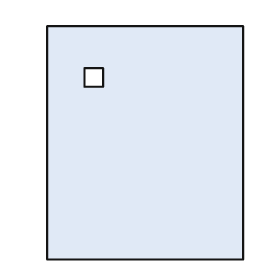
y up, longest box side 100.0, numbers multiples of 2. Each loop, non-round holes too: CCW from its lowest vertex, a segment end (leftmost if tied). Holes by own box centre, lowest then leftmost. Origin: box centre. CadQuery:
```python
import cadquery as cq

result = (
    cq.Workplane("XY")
    .moveTo(-42.0, -50.0)
    .lineTo(42.0, -50.0)
    .lineTo(42.0, 50.0)
    .lineTo(-42.0, 50.0)
    .close()
    .moveTo(-26.0, 24.0)
    .lineTo(-18.0, 24.0)
    .lineTo(-18.0, 32.0)
    .lineTo(-26.0, 32.0)
    .close()
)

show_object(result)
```